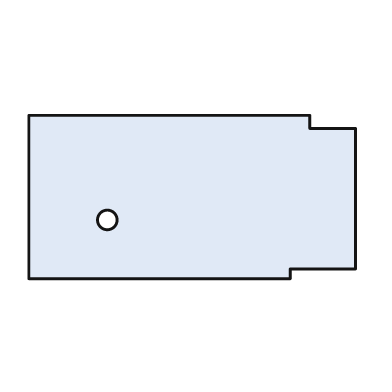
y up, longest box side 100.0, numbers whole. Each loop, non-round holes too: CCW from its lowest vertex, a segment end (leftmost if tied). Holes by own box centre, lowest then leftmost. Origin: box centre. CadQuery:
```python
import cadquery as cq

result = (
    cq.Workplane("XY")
    .moveTo(-50.0, -25.0)
    .lineTo(30.0, -25.0)
    .lineTo(30.0, -22.0)
    .lineTo(50.0, -22.0)
    .lineTo(50.0, 21.0)
    .lineTo(36.0, 21.0)
    .lineTo(36.0, 25.0)
    .lineTo(-50.0, 25.0)
    .close()
    .moveTo(-26.0, -7.0)
    .circle(3.0)
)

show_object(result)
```